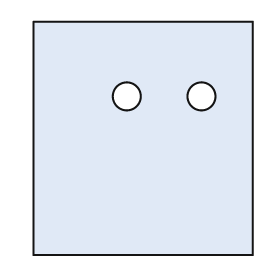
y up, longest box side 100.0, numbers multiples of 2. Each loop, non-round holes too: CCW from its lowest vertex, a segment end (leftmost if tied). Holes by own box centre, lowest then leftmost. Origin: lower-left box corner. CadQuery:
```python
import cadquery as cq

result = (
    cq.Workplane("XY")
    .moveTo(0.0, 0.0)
    .lineTo(94.0, 0.0)
    .lineTo(94.0, 100.0)
    .lineTo(0.0, 100.0)
    .close()
    .moveTo(40.0, 68.0)
    .circle(6.0)
    .moveTo(72.0, 68.0)
    .circle(6.0)
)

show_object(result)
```